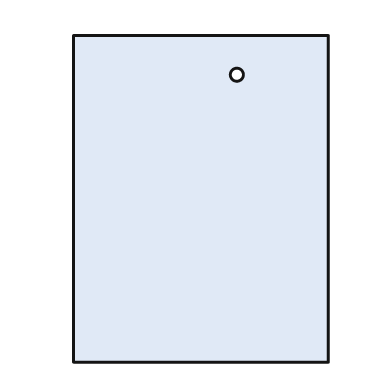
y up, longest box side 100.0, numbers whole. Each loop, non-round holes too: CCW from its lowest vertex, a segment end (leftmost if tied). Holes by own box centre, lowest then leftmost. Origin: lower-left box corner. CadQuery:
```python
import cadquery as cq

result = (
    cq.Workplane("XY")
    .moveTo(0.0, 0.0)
    .lineTo(78.0, 0.0)
    .lineTo(78.0, 100.0)
    .lineTo(0.0, 100.0)
    .close()
    .moveTo(50.0, 88.0)
    .circle(2.0)
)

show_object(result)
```